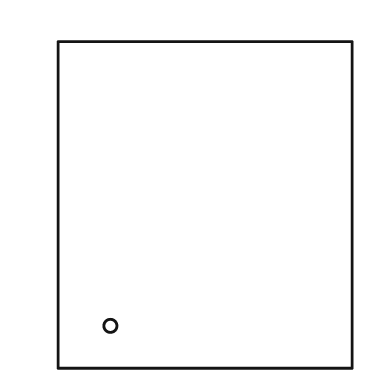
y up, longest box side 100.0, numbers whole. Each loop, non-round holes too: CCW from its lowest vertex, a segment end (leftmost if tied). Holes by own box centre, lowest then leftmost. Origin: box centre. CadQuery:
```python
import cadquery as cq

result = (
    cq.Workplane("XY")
    .moveTo(-45.0, -50.0)
    .lineTo(45.0, -50.0)
    .lineTo(45.0, 50.0)
    .lineTo(-45.0, 50.0)
    .close()
    .moveTo(-29.0, -37.0)
    .circle(2.0)
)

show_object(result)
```